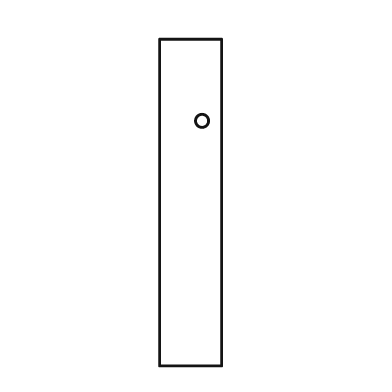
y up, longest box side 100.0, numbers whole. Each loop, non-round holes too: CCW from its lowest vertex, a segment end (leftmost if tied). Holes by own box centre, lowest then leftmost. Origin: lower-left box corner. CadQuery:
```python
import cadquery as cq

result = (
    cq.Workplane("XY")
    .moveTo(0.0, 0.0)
    .lineTo(19.0, 0.0)
    .lineTo(19.0, 100.0)
    .lineTo(0.0, 100.0)
    .close()
    .moveTo(13.0, 75.0)
    .circle(2.0)
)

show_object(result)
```